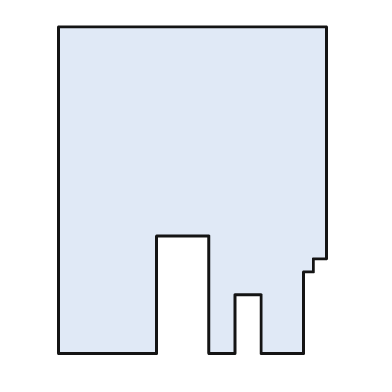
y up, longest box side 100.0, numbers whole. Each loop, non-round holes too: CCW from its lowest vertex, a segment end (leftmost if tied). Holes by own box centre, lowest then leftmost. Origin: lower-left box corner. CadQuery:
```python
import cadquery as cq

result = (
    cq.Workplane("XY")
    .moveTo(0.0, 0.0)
    .lineTo(30.0, 0.0)
    .lineTo(30.0, 36.0)
    .lineTo(46.0, 36.0)
    .lineTo(46.0, 0.0)
    .lineTo(54.0, 0.0)
    .lineTo(54.0, 18.0)
    .lineTo(62.0, 18.0)
    .lineTo(62.0, 0.0)
    .lineTo(75.0, 0.0)
    .lineTo(75.0, 25.0)
    .lineTo(78.0, 25.0)
    .lineTo(78.0, 29.0)
    .lineTo(82.0, 29.0)
    .lineTo(82.0, 100.0)
    .lineTo(0.0, 100.0)
    .close()
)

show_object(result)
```